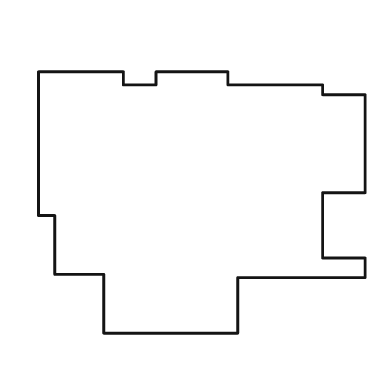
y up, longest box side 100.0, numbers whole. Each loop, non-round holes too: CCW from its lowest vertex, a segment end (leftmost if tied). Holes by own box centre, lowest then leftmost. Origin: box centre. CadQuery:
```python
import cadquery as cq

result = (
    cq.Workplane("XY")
    .moveTo(-30.0, -40.0)
    .lineTo(11.0, -40.0)
    .lineTo(11.0, -23.0)
    .lineTo(50.0, -23.0)
    .lineTo(50.0, -17.0)
    .lineTo(37.0, -17.0)
    .lineTo(37.0, 3.0)
    .lineTo(50.0, 3.0)
    .lineTo(50.0, 33.0)
    .lineTo(37.0, 33.0)
    .lineTo(37.0, 36.0)
    .lineTo(8.0, 36.0)
    .lineTo(8.0, 40.0)
    .lineTo(-14.0, 40.0)
    .lineTo(-14.0, 36.0)
    .lineTo(-24.0, 36.0)
    .lineTo(-24.0, 40.0)
    .lineTo(-50.0, 40.0)
    .lineTo(-50.0, -4.0)
    .lineTo(-45.0, -4.0)
    .lineTo(-45.0, -22.0)
    .lineTo(-30.0, -22.0)
    .close()
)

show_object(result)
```